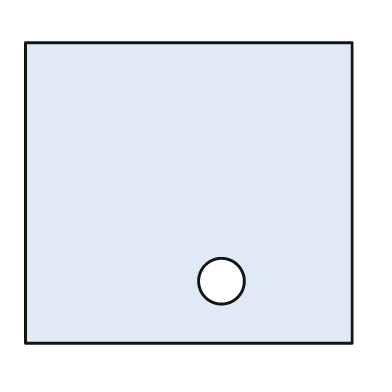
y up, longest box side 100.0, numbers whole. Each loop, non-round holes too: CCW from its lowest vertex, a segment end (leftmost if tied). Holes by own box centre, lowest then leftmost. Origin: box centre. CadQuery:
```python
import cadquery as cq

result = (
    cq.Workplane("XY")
    .moveTo(-50.0, -46.0)
    .lineTo(50.0, -46.0)
    .lineTo(50.0, 46.0)
    .lineTo(-50.0, 46.0)
    .close()
    .moveTo(10.0, -27.0)
    .circle(7.0)
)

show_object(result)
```